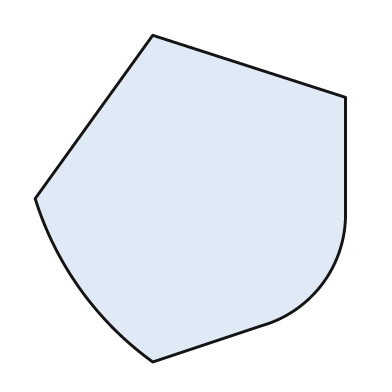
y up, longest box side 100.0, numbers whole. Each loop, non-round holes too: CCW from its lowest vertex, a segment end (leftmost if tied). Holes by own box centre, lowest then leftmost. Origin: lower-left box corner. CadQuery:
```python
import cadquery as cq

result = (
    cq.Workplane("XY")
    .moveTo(36.0, 0.0)
    .lineTo(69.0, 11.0)
    .threePointArc((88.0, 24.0), (95.0, 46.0))
    .lineTo(95.0, 81.0)
    .lineTo(36.0, 100.0)
    .lineTo(0.0, 50.0)
    .threePointArc((14.0, 22.0), (36.0, 0.0))
    .close()
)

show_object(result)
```